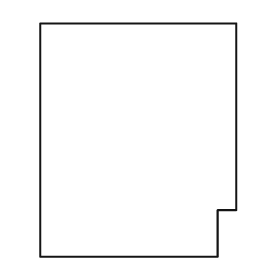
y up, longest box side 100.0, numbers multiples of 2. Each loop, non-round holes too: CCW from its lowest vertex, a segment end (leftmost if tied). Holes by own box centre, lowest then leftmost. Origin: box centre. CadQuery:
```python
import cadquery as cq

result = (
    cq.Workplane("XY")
    .moveTo(-42.0, -50.0)
    .lineTo(34.0, -50.0)
    .lineTo(34.0, -30.0)
    .lineTo(42.0, -30.0)
    .lineTo(42.0, 50.0)
    .lineTo(-42.0, 50.0)
    .close()
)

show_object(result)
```